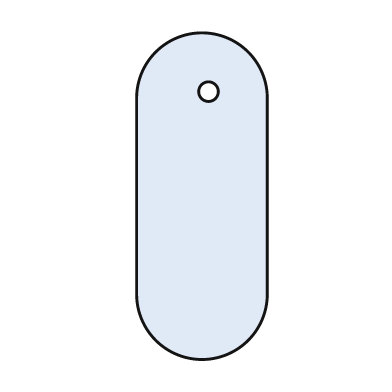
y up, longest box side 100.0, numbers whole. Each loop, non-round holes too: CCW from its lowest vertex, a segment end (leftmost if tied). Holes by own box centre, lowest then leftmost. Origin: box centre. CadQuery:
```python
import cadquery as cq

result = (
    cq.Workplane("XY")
    .moveTo(-20.0, -30.0)
    .threePointArc((0.0, -50.0), (20.0, -30.0))
    .lineTo(20.0, 30.0)
    .threePointArc((0.0, 50.0), (-20.0, 30.0))
    .close()
    .moveTo(2.0, 32.0)
    .circle(3.0)
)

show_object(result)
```